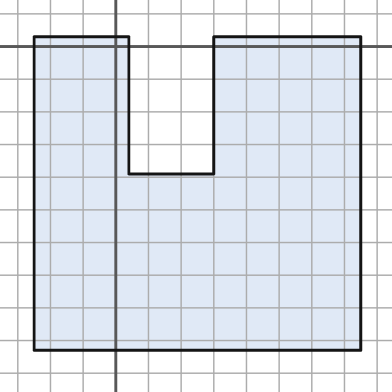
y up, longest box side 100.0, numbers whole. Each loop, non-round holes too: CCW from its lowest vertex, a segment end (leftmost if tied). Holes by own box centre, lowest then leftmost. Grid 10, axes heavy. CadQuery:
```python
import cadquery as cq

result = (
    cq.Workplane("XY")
    .moveTo(-25.0, -93.0)
    .lineTo(75.0, -93.0)
    .lineTo(75.0, 3.0)
    .lineTo(30.0, 3.0)
    .lineTo(30.0, -39.0)
    .lineTo(4.0, -39.0)
    .lineTo(4.0, 3.0)
    .lineTo(-25.0, 3.0)
    .close()
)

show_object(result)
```